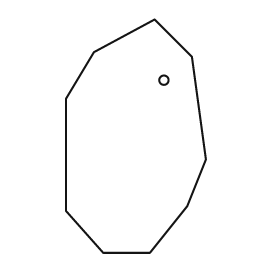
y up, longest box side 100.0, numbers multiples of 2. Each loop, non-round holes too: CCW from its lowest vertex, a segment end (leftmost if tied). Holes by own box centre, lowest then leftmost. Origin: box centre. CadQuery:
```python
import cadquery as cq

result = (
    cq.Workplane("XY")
    .moveTo(-14.0, -50.0)
    .lineTo(6.0, -50.0)
    .lineTo(22.0, -30.0)
    .lineTo(30.0, -10.0)
    .lineTo(24.0, 34.0)
    .lineTo(8.0, 50.0)
    .lineTo(-18.0, 36.0)
    .lineTo(-30.0, 16.0)
    .lineTo(-30.0, -32.0)
    .close()
    .moveTo(12.0, 24.0)
    .circle(2.0)
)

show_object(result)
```